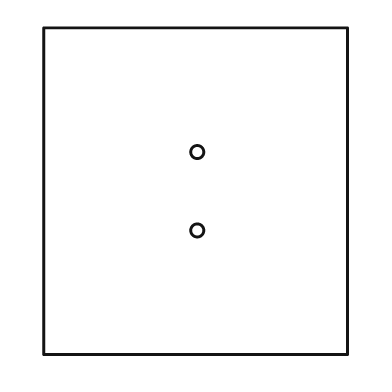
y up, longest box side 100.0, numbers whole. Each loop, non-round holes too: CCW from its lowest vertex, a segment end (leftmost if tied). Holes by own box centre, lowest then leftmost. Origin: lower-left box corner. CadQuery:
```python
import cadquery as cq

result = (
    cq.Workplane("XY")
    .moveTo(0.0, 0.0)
    .lineTo(93.0, 0.0)
    .lineTo(93.0, 100.0)
    .lineTo(0.0, 100.0)
    .close()
    .moveTo(47.0, 38.0)
    .circle(2.0)
    .moveTo(47.0, 62.0)
    .circle(2.0)
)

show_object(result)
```